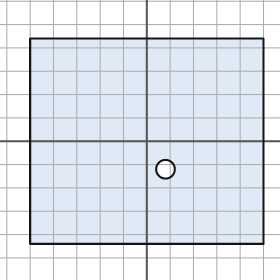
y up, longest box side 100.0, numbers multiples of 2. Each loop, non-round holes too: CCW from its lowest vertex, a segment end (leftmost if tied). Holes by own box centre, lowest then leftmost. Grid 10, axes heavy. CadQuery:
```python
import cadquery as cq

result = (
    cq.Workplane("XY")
    .moveTo(-50.0, -44.0)
    .lineTo(50.0, -44.0)
    .lineTo(50.0, 44.0)
    .lineTo(-50.0, 44.0)
    .close()
    .moveTo(8.0, -12.0)
    .circle(4.0)
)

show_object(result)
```